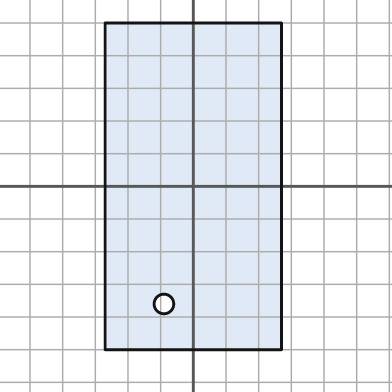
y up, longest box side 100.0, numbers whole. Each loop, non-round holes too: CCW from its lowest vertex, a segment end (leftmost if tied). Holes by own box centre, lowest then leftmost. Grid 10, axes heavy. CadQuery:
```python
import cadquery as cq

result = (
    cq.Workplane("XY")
    .moveTo(-27.0, -50.0)
    .lineTo(27.0, -50.0)
    .lineTo(27.0, 50.0)
    .lineTo(-27.0, 50.0)
    .close()
    .moveTo(-9.0, -36.0)
    .circle(3.0)
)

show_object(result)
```